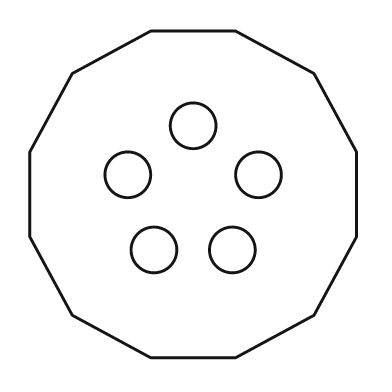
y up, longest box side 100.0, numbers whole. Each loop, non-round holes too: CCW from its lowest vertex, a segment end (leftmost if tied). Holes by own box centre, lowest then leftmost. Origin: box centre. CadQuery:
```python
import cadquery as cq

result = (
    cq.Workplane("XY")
    .moveTo(-13.0, -50.0)
    .lineTo(13.0, -50.0)
    .lineTo(37.0, -37.0)
    .lineTo(50.0, -13.0)
    .lineTo(50.0, 13.0)
    .lineTo(37.0, 37.0)
    .lineTo(13.0, 50.0)
    .lineTo(-13.0, 50.0)
    .lineTo(-37.0, 37.0)
    .lineTo(-50.0, 13.0)
    .lineTo(-50.0, -13.0)
    .lineTo(-37.0, -37.0)
    .close()
    .moveTo(-12.0, -17.0)
    .circle(7.0)
    .moveTo(12.0, -17.0)
    .circle(7.0)
    .moveTo(-20.0, 6.0)
    .circle(7.0)
    .moveTo(20.0, 6.0)
    .circle(7.0)
    .moveTo(0.0, 21.0)
    .circle(7.0)
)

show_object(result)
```